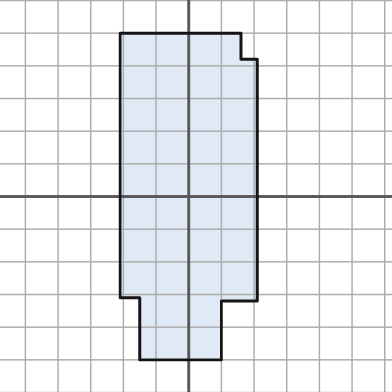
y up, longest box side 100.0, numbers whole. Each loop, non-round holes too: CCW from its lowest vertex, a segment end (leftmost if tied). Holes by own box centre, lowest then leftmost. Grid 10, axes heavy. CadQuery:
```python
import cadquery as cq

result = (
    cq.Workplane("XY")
    .moveTo(-15.0, -50.0)
    .lineTo(10.0, -50.0)
    .lineTo(10.0, -32.0)
    .lineTo(21.0, -32.0)
    .lineTo(21.0, 42.0)
    .lineTo(16.0, 42.0)
    .lineTo(16.0, 50.0)
    .lineTo(-21.0, 50.0)
    .lineTo(-21.0, -31.0)
    .lineTo(-15.0, -31.0)
    .close()
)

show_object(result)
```